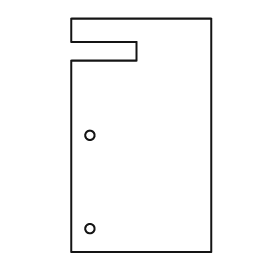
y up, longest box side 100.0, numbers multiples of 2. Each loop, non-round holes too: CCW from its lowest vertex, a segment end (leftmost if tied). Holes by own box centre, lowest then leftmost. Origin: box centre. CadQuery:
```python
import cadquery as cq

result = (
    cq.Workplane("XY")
    .moveTo(-30.0, -50.0)
    .lineTo(30.0, -50.0)
    .lineTo(30.0, 50.0)
    .lineTo(-30.0, 50.0)
    .lineTo(-30.0, 40.0)
    .lineTo(-2.0, 40.0)
    .lineTo(-2.0, 32.0)
    .lineTo(-30.0, 32.0)
    .close()
    .moveTo(-22.0, -40.0)
    .circle(2.0)
    .moveTo(-22.0, 0.0)
    .circle(2.0)
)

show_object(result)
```